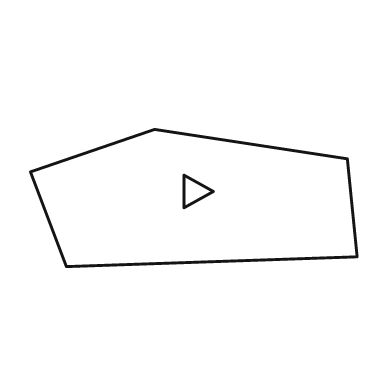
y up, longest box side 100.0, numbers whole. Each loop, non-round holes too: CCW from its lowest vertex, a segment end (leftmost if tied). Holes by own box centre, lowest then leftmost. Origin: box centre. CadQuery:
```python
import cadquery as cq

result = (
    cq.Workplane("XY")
    .moveTo(-39.0, -21.0)
    .lineTo(50.0, -18.0)
    .lineTo(47.0, 12.0)
    .lineTo(-12.0, 21.0)
    .lineTo(-50.0, 8.0)
    .close()
    .moveTo(-3.0, -3.0)
    .lineTo(6.0, 2.0)
    .lineTo(-3.0, 7.0)
    .close()
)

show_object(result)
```